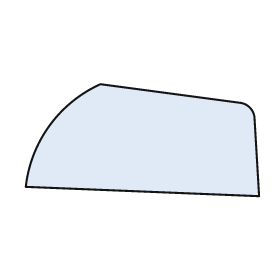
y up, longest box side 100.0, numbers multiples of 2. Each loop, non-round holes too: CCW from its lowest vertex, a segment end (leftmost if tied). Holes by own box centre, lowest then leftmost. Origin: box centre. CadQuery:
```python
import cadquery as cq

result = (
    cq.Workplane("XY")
    .moveTo(50.0, -24.0)
    .lineTo(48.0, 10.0)
    .threePointArc((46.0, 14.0), (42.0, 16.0))
    .lineTo(-18.0, 24.0)
    .threePointArc((-40.0, 6.0), (-50.0, -20.0))
    .close()
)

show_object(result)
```